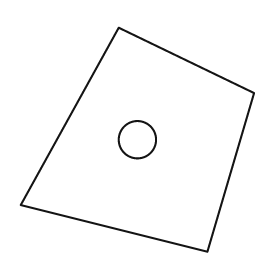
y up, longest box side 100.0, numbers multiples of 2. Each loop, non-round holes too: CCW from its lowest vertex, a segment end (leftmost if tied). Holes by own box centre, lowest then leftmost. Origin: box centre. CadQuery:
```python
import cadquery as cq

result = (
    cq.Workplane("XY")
    .moveTo(30.0, -48.0)
    .lineTo(50.0, 20.0)
    .lineTo(-8.0, 48.0)
    .lineTo(-50.0, -28.0)
    .close()
    .moveTo(0.0, 0.0)
    .circle(8.0)
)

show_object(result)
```